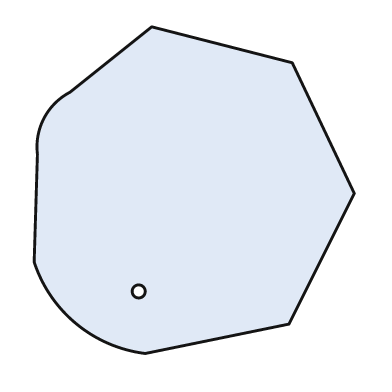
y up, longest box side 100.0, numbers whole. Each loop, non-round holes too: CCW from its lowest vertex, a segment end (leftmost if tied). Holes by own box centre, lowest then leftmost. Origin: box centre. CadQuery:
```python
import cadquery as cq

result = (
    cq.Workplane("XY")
    .moveTo(-15.0, -50.0)
    .lineTo(29.0, -41.0)
    .lineTo(49.0, -1.0)
    .lineTo(30.0, 39.0)
    .lineTo(-13.0, 50.0)
    .lineTo(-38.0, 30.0)
    .threePointArc((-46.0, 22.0), (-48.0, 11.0))
    .lineTo(-49.0, -22.0)
    .threePointArc((-36.0, -41.0), (-15.0, -50.0))
    .close()
    .moveTo(-17.0, -31.0)
    .circle(2.0)
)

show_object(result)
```